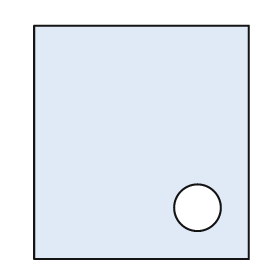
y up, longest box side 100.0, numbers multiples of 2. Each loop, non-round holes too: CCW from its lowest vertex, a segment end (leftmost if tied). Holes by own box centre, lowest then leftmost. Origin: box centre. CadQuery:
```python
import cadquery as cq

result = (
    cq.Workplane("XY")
    .moveTo(-46.0, -50.0)
    .lineTo(46.0, -50.0)
    .lineTo(46.0, 50.0)
    .lineTo(-46.0, 50.0)
    .close()
    .moveTo(24.0, -28.0)
    .circle(10.0)
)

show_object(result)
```